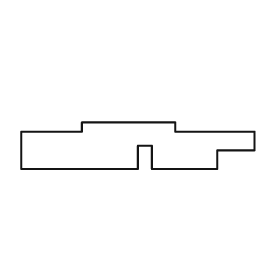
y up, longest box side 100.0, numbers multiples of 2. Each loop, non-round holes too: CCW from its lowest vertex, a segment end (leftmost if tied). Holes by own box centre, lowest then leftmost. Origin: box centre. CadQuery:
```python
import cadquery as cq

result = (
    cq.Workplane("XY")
    .moveTo(-50.0, -10.0)
    .lineTo(0.0, -10.0)
    .lineTo(0.0, 0.0)
    .lineTo(6.0, 0.0)
    .lineTo(6.0, -10.0)
    .lineTo(34.0, -10.0)
    .lineTo(34.0, -2.0)
    .lineTo(50.0, -2.0)
    .lineTo(50.0, 6.0)
    .lineTo(16.0, 6.0)
    .lineTo(16.0, 10.0)
    .lineTo(-24.0, 10.0)
    .lineTo(-24.0, 6.0)
    .lineTo(-50.0, 6.0)
    .close()
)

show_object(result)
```